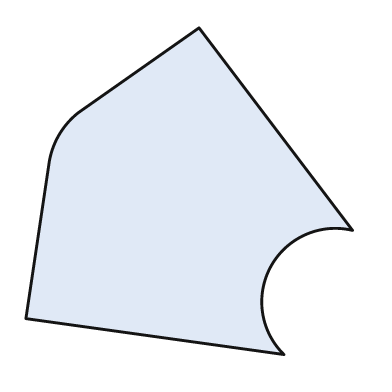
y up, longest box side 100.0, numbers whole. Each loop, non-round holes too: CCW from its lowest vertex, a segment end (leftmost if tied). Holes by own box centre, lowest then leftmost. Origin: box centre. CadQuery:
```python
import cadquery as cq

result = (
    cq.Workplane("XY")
    .moveTo(29.0, -50.0)
    .threePointArc((25.0, -23.0), (50.0, -12.0))
    .lineTo(3.0, 50.0)
    .lineTo(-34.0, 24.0)
    .threePointArc((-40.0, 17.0), (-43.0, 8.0))
    .lineTo(-50.0, -39.0)
    .close()
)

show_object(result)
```